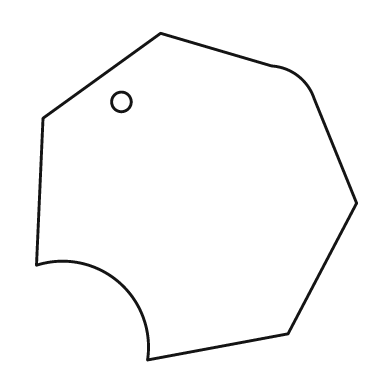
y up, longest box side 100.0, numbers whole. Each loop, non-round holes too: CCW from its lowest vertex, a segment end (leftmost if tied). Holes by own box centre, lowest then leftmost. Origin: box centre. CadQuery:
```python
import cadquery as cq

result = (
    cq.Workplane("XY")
    .moveTo(-15.0, -50.0)
    .lineTo(28.0, -42.0)
    .lineTo(49.0, -2.0)
    .lineTo(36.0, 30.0)
    .threePointArc((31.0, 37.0), (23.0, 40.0))
    .lineTo(-11.0, 50.0)
    .lineTo(-47.0, 24.0)
    .lineTo(-49.0, -21.0)
    .threePointArc((-24.0, -26.0), (-15.0, -50.0))
    .close()
    .moveTo(-23.0, 29.0)
    .circle(3.0)
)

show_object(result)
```